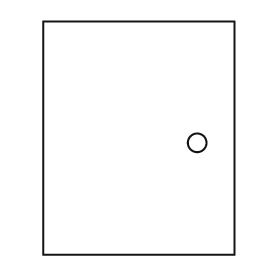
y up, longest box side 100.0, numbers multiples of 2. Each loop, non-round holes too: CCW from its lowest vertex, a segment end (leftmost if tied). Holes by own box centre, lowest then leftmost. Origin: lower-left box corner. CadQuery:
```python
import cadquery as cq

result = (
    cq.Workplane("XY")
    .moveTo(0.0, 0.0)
    .lineTo(82.0, 0.0)
    .lineTo(82.0, 100.0)
    .lineTo(0.0, 100.0)
    .close()
    .moveTo(66.0, 48.0)
    .circle(4.0)
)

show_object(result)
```